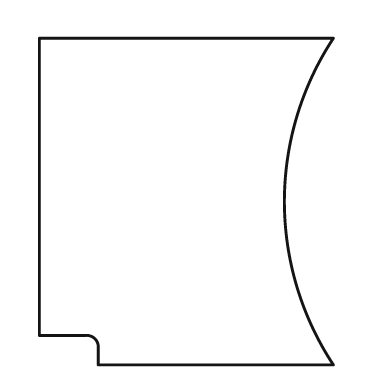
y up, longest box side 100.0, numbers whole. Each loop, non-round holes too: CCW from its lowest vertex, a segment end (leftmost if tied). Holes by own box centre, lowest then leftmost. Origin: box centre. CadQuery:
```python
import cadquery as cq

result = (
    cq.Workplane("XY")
    .moveTo(-27.0, -50.0)
    .lineTo(45.0, -50.0)
    .threePointArc((30.0, 0.0), (45.0, 50.0))
    .lineTo(-45.0, 50.0)
    .lineTo(-45.0, -41.0)
    .lineTo(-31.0, -41.0)
    .threePointArc((-28.0, -42.0), (-27.0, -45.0))
    .close()
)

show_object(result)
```